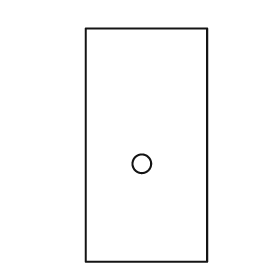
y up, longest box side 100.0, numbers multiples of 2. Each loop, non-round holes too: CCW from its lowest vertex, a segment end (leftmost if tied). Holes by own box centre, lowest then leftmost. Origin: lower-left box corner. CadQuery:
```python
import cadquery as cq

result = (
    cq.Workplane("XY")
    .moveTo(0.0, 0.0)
    .lineTo(52.0, 0.0)
    .lineTo(52.0, 100.0)
    .lineTo(0.0, 100.0)
    .close()
    .moveTo(24.0, 42.0)
    .circle(4.0)
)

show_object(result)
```